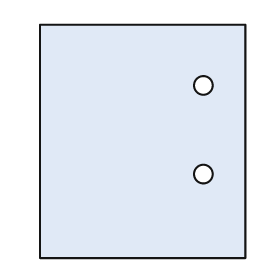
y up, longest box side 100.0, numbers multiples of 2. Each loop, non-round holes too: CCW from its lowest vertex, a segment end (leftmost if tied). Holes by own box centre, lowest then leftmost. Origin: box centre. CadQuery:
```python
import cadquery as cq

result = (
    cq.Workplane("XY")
    .moveTo(-44.0, -50.0)
    .lineTo(44.0, -50.0)
    .lineTo(44.0, 50.0)
    .lineTo(-44.0, 50.0)
    .close()
    .moveTo(26.0, -14.0)
    .circle(4.0)
    .moveTo(26.0, 24.0)
    .circle(4.0)
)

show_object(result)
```